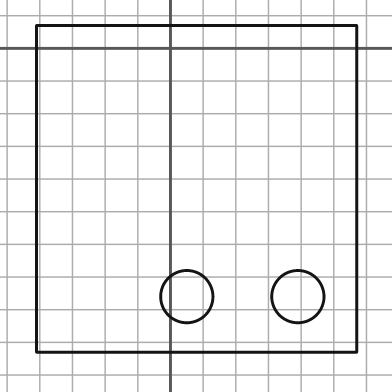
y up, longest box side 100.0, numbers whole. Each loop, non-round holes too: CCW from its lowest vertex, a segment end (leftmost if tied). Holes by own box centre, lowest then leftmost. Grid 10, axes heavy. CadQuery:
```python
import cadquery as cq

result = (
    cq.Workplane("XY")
    .moveTo(-41.0, -93.0)
    .lineTo(57.0, -93.0)
    .lineTo(57.0, 7.0)
    .lineTo(-41.0, 7.0)
    .close()
    .moveTo(5.0, -76.0)
    .circle(8.0)
    .moveTo(39.0, -76.0)
    .circle(8.0)
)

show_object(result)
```